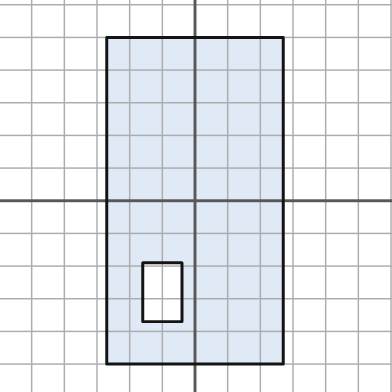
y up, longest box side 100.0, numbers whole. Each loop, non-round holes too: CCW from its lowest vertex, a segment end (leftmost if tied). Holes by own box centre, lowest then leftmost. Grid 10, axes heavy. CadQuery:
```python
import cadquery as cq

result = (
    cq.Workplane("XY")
    .moveTo(-27.0, -50.0)
    .lineTo(27.0, -50.0)
    .lineTo(27.0, 50.0)
    .lineTo(-27.0, 50.0)
    .close()
    .moveTo(-16.0, -37.0)
    .lineTo(-4.0, -37.0)
    .lineTo(-4.0, -19.0)
    .lineTo(-16.0, -19.0)
    .close()
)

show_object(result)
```